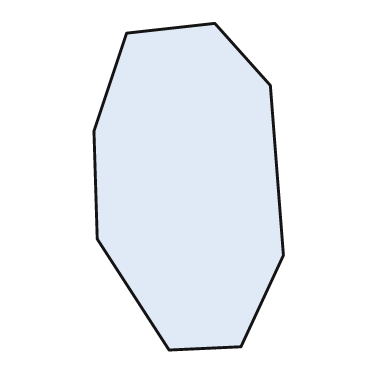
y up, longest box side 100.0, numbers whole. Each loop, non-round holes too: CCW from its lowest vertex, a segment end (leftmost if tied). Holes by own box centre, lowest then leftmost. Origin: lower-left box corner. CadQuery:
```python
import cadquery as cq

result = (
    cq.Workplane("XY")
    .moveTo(23.0, 0.0)
    .lineTo(45.0, 1.0)
    .lineTo(58.0, 29.0)
    .lineTo(54.0, 81.0)
    .lineTo(37.0, 100.0)
    .lineTo(10.0, 97.0)
    .lineTo(0.0, 67.0)
    .lineTo(1.0, 34.0)
    .close()
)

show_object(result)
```